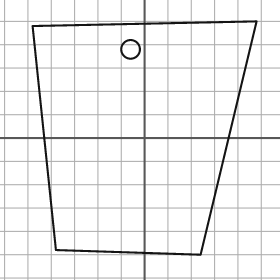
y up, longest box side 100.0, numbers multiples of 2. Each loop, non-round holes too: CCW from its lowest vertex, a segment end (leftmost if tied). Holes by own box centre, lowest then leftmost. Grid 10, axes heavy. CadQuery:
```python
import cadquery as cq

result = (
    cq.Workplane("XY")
    .moveTo(24.0, -50.0)
    .lineTo(48.0, 50.0)
    .lineTo(-48.0, 48.0)
    .lineTo(-38.0, -48.0)
    .close()
    .moveTo(-6.0, 38.0)
    .circle(4.0)
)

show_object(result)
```